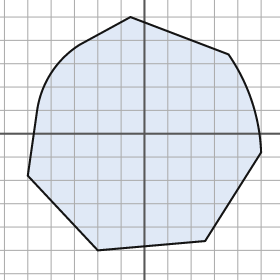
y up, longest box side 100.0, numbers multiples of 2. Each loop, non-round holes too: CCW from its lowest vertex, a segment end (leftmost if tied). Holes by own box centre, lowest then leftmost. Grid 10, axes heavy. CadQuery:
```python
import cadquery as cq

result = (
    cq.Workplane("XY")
    .moveTo(-20.0, -50.0)
    .lineTo(26.0, -46.0)
    .lineTo(50.0, -8.0)
    .threePointArc((46.0, 14.0), (36.0, 34.0))
    .lineTo(-6.0, 50.0)
    .lineTo(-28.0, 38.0)
    .threePointArc((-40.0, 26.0), (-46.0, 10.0))
    .lineTo(-50.0, -18.0)
    .close()
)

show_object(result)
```